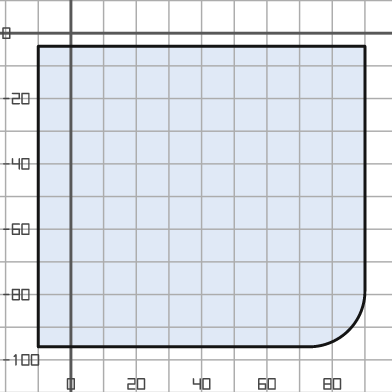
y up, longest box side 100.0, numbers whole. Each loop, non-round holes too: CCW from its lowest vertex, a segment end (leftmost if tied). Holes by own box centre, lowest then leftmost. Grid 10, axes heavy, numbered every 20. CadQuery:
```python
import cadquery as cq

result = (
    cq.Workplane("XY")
    .moveTo(-10.0, -96.0)
    .lineTo(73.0, -96.0)
    .threePointArc((85.0, -91.0), (90.0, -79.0))
    .lineTo(90.0, -4.0)
    .lineTo(-10.0, -4.0)
    .close()
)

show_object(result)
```